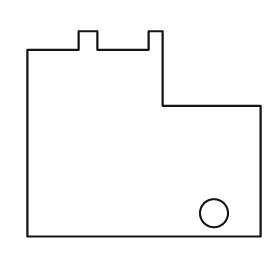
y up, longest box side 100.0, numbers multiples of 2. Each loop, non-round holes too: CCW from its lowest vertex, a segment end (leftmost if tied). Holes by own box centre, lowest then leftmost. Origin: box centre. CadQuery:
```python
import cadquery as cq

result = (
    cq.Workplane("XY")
    .moveTo(-50.0, -44.0)
    .lineTo(50.0, -44.0)
    .lineTo(50.0, 12.0)
    .lineTo(8.0, 12.0)
    .lineTo(8.0, 44.0)
    .lineTo(2.0, 44.0)
    .lineTo(2.0, 36.0)
    .lineTo(-20.0, 36.0)
    .lineTo(-20.0, 44.0)
    .lineTo(-28.0, 44.0)
    .lineTo(-28.0, 36.0)
    .lineTo(-50.0, 36.0)
    .close()
    .moveTo(30.0, -34.0)
    .circle(6.0)
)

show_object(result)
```